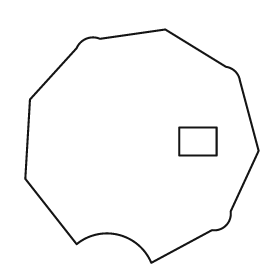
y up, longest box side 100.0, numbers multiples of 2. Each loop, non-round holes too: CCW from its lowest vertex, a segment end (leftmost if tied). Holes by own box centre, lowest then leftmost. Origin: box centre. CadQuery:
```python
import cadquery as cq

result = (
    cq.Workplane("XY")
    .moveTo(4.0, -50.0)
    .lineTo(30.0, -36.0)
    .threePointArc((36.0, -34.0), (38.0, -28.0))
    .lineTo(50.0, -2.0)
    .lineTo(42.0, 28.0)
    .threePointArc((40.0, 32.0), (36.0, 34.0))
    .lineTo(10.0, 50.0)
    .lineTo(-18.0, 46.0)
    .threePointArc((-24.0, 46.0), (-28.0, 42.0))
    .lineTo(-48.0, 20.0)
    .lineTo(-50.0, -14.0)
    .lineTo(-28.0, -42.0)
    .threePointArc((-10.0, -38.0), (4.0, -50.0))
    .close()
    .moveTo(16.0, -4.0)
    .lineTo(32.0, -4.0)
    .lineTo(32.0, 8.0)
    .lineTo(16.0, 8.0)
    .close()
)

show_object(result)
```